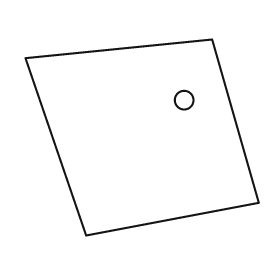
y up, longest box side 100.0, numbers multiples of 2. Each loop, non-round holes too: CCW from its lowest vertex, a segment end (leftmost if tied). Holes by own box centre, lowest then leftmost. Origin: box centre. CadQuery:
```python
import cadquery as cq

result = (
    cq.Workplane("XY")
    .moveTo(-24.0, -42.0)
    .lineTo(50.0, -28.0)
    .lineTo(30.0, 42.0)
    .lineTo(-50.0, 34.0)
    .close()
    .moveTo(18.0, 16.0)
    .circle(4.0)
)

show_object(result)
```